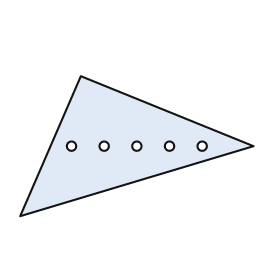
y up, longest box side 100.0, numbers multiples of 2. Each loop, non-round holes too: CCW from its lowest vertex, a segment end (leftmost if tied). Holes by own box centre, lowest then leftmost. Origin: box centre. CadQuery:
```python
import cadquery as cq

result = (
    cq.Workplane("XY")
    .moveTo(-50.0, -30.0)
    .lineTo(50.0, 0.0)
    .lineTo(-24.0, 30.0)
    .close()
    .moveTo(-28.0, 0.0)
    .circle(2.0)
    .moveTo(-14.0, 0.0)
    .circle(2.0)
    .moveTo(0.0, 0.0)
    .circle(2.0)
    .moveTo(14.0, 0.0)
    .circle(2.0)
    .moveTo(28.0, 0.0)
    .circle(2.0)
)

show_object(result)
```